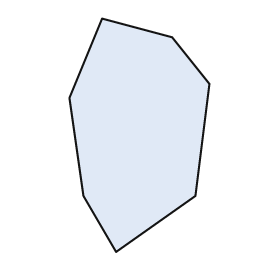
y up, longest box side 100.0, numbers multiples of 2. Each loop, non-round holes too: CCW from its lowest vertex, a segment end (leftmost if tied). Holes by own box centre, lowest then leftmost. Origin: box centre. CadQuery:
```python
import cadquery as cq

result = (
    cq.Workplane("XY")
    .moveTo(-10.0, -50.0)
    .lineTo(24.0, -26.0)
    .lineTo(30.0, 22.0)
    .lineTo(14.0, 42.0)
    .lineTo(-16.0, 50.0)
    .lineTo(-30.0, 16.0)
    .lineTo(-24.0, -26.0)
    .close()
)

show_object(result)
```